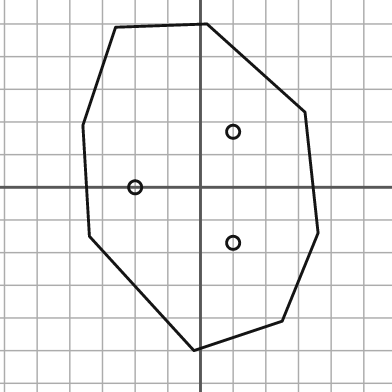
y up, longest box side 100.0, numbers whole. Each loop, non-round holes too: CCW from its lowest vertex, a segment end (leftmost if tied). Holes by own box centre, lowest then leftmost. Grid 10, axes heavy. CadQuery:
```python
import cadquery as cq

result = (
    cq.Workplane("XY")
    .moveTo(-2.0, -50.0)
    .lineTo(25.0, -41.0)
    .lineTo(36.0, -14.0)
    .lineTo(32.0, 23.0)
    .lineTo(2.0, 50.0)
    .lineTo(-26.0, 49.0)
    .lineTo(-36.0, 19.0)
    .lineTo(-34.0, -15.0)
    .close()
    .moveTo(10.0, -17.0)
    .circle(2.0)
    .moveTo(-20.0, 0.0)
    .circle(2.0)
    .moveTo(10.0, 17.0)
    .circle(2.0)
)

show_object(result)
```